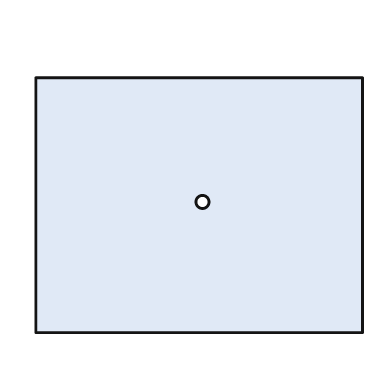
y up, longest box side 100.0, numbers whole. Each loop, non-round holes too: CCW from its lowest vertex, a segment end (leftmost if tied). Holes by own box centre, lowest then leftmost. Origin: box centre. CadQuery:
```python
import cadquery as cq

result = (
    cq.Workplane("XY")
    .moveTo(-50.0, -39.0)
    .lineTo(50.0, -39.0)
    .lineTo(50.0, 39.0)
    .lineTo(-50.0, 39.0)
    .close()
    .moveTo(1.0, 1.0)
    .circle(2.0)
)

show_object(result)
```